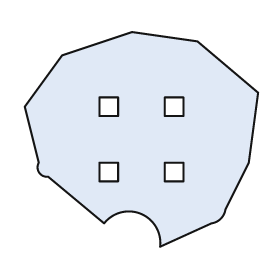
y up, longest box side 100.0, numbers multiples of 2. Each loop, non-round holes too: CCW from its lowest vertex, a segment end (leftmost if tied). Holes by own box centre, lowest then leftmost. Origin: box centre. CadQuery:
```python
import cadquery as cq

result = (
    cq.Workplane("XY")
    .moveTo(8.0, -46.0)
    .lineTo(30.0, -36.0)
    .threePointArc((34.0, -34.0), (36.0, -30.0))
    .lineTo(46.0, -10.0)
    .lineTo(50.0, 20.0)
    .lineTo(24.0, 42.0)
    .lineTo(-4.0, 46.0)
    .lineTo(-34.0, 36.0)
    .lineTo(-50.0, 14.0)
    .lineTo(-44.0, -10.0)
    .threePointArc((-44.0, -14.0), (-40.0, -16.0))
    .lineTo(-16.0, -36.0)
    .threePointArc((0.0, -32.0), (8.0, -46.0))
    .close()
    .moveTo(-18.0, -18.0)
    .lineTo(-10.0, -18.0)
    .lineTo(-10.0, -10.0)
    .lineTo(-18.0, -10.0)
    .close()
    .moveTo(10.0, -18.0)
    .lineTo(18.0, -18.0)
    .lineTo(18.0, -10.0)
    .lineTo(10.0, -10.0)
    .close()
    .moveTo(-18.0, 10.0)
    .lineTo(-10.0, 10.0)
    .lineTo(-10.0, 18.0)
    .lineTo(-18.0, 18.0)
    .close()
    .moveTo(10.0, 10.0)
    .lineTo(18.0, 10.0)
    .lineTo(18.0, 18.0)
    .lineTo(10.0, 18.0)
    .close()
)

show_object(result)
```